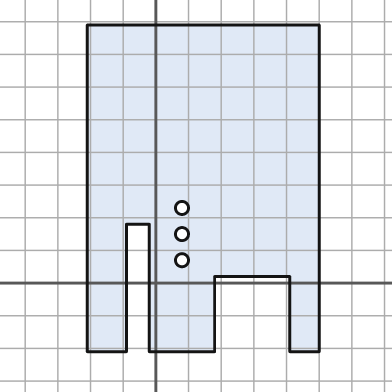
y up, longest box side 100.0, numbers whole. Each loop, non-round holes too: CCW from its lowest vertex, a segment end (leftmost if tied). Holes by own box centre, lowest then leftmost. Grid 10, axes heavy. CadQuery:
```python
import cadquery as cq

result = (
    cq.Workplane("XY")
    .moveTo(-21.0, -21.0)
    .lineTo(-9.0, -21.0)
    .lineTo(-9.0, 18.0)
    .lineTo(-2.0, 18.0)
    .lineTo(-2.0, -21.0)
    .lineTo(18.0, -21.0)
    .lineTo(18.0, 2.0)
    .lineTo(41.0, 2.0)
    .lineTo(41.0, -21.0)
    .lineTo(50.0, -21.0)
    .lineTo(50.0, 79.0)
    .lineTo(-21.0, 79.0)
    .close()
    .moveTo(8.0, 7.0)
    .circle(2.0)
    .moveTo(8.0, 15.0)
    .circle(2.0)
    .moveTo(8.0, 23.0)
    .circle(2.0)
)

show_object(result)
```